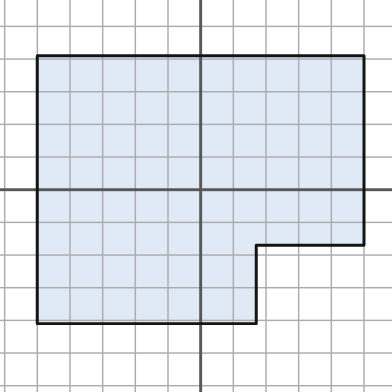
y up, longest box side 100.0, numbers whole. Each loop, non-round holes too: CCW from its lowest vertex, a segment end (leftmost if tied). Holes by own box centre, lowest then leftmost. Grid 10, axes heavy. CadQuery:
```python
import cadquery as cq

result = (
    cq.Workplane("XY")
    .moveTo(-50.0, -41.0)
    .lineTo(17.0, -41.0)
    .lineTo(17.0, -17.0)
    .lineTo(50.0, -17.0)
    .lineTo(50.0, 41.0)
    .lineTo(-50.0, 41.0)
    .close()
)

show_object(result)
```